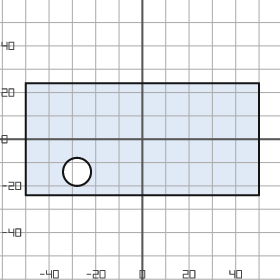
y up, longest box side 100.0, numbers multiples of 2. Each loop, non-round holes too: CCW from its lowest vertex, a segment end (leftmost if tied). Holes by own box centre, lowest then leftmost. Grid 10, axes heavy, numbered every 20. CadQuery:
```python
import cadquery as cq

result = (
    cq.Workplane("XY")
    .moveTo(-50.0, -24.0)
    .lineTo(50.0, -24.0)
    .lineTo(50.0, 24.0)
    .lineTo(-50.0, 24.0)
    .close()
    .moveTo(-28.0, -14.0)
    .circle(6.0)
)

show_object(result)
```